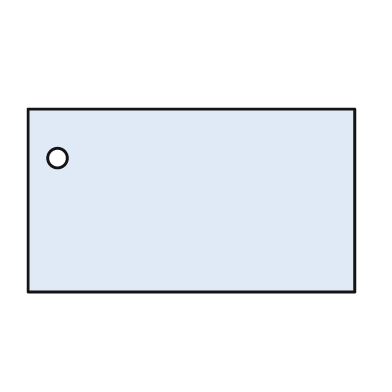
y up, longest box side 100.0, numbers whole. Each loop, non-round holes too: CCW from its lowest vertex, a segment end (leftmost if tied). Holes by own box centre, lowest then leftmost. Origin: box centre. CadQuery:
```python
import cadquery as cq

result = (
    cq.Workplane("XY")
    .moveTo(-50.0, -28.0)
    .lineTo(50.0, -28.0)
    .lineTo(50.0, 28.0)
    .lineTo(-50.0, 28.0)
    .close()
    .moveTo(-41.0, 13.0)
    .circle(3.0)
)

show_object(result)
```